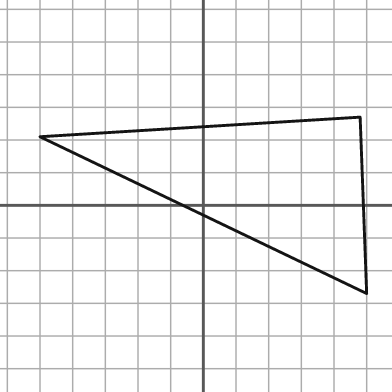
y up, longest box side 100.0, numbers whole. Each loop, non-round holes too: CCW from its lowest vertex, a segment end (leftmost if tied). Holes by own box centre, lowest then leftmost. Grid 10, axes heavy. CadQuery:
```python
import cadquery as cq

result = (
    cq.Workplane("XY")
    .moveTo(50.0, -27.0)
    .lineTo(48.0, 27.0)
    .lineTo(-50.0, 21.0)
    .close()
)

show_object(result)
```